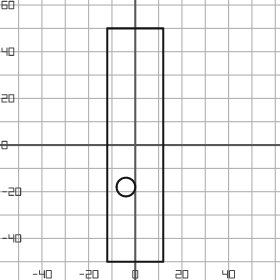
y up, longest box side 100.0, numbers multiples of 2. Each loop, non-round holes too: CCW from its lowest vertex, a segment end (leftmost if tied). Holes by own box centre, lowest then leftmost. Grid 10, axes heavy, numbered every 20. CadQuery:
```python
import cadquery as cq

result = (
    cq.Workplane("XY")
    .moveTo(-12.0, -50.0)
    .lineTo(12.0, -50.0)
    .lineTo(12.0, 50.0)
    .lineTo(-12.0, 50.0)
    .close()
    .moveTo(-4.0, -18.0)
    .circle(4.0)
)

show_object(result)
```